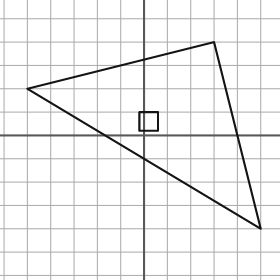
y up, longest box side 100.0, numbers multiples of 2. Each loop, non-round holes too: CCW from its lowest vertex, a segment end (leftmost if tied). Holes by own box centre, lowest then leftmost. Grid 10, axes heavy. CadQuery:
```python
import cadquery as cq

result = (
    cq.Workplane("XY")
    .moveTo(50.0, -40.0)
    .lineTo(30.0, 40.0)
    .lineTo(-50.0, 20.0)
    .close()
    .moveTo(-2.0, 2.0)
    .lineTo(6.0, 2.0)
    .lineTo(6.0, 10.0)
    .lineTo(-2.0, 10.0)
    .close()
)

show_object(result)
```